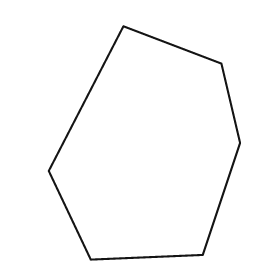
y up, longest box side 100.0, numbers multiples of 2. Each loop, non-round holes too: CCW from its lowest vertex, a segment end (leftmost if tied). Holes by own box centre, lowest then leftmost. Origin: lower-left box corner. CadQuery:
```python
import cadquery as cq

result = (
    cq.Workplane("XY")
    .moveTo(18.0, 0.0)
    .lineTo(66.0, 2.0)
    .lineTo(82.0, 50.0)
    .lineTo(74.0, 84.0)
    .lineTo(32.0, 100.0)
    .lineTo(0.0, 38.0)
    .close()
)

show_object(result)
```